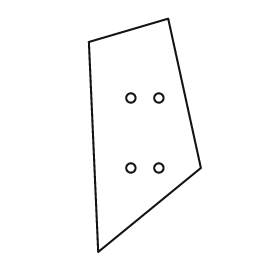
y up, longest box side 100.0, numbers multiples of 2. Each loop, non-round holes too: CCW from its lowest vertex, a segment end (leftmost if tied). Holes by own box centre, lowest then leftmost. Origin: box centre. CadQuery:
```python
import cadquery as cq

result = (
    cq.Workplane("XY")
    .moveTo(-20.0, -50.0)
    .lineTo(24.0, -14.0)
    .lineTo(10.0, 50.0)
    .lineTo(-24.0, 40.0)
    .close()
    .moveTo(-6.0, -14.0)
    .circle(2.0)
    .moveTo(6.0, -14.0)
    .circle(2.0)
    .moveTo(-6.0, 16.0)
    .circle(2.0)
    .moveTo(6.0, 16.0)
    .circle(2.0)
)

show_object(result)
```